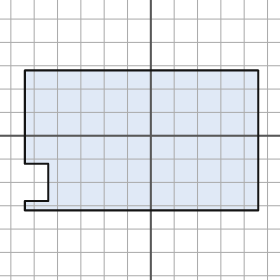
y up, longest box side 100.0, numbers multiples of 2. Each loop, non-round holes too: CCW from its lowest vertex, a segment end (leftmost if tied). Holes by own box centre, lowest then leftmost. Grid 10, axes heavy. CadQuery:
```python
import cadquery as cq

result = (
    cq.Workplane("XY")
    .moveTo(-54.0, -32.0)
    .lineTo(46.0, -32.0)
    .lineTo(46.0, 28.0)
    .lineTo(-54.0, 28.0)
    .lineTo(-54.0, -12.0)
    .lineTo(-44.0, -12.0)
    .lineTo(-44.0, -28.0)
    .lineTo(-54.0, -28.0)
    .close()
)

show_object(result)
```